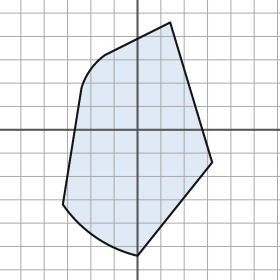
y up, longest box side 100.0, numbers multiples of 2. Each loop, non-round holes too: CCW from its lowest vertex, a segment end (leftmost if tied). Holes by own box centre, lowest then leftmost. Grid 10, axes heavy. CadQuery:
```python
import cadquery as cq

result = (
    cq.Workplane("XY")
    .moveTo(0.0, -54.0)
    .lineTo(32.0, -14.0)
    .lineTo(14.0, 46.0)
    .lineTo(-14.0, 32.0)
    .threePointArc((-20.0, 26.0), (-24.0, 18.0))
    .lineTo(-32.0, -32.0)
    .threePointArc((-18.0, -46.0), (0.0, -54.0))
    .close()
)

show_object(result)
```